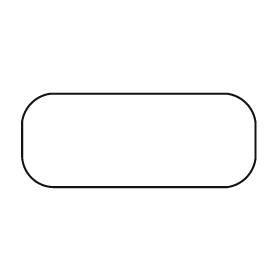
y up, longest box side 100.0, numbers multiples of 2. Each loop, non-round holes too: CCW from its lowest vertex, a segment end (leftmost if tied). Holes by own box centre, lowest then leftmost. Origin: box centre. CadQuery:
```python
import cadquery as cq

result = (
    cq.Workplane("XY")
    .moveTo(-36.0, -20.0)
    .lineTo(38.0, -20.0)
    .threePointArc((46.0, -16.0), (50.0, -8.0))
    .lineTo(50.0, 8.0)
    .threePointArc((46.0, 16.0), (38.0, 20.0))
    .lineTo(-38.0, 20.0)
    .threePointArc((-46.0, 16.0), (-50.0, 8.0))
    .lineTo(-50.0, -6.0)
    .threePointArc((-46.0, -16.0), (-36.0, -20.0))
    .close()
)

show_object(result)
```